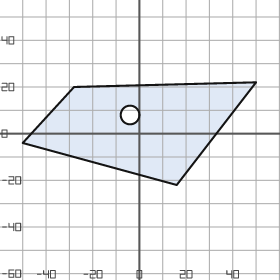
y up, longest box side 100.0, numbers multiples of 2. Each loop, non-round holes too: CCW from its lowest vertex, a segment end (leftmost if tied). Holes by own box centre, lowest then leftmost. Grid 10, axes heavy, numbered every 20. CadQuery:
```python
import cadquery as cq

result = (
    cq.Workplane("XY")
    .moveTo(16.0, -22.0)
    .lineTo(50.0, 22.0)
    .lineTo(-28.0, 20.0)
    .lineTo(-50.0, -4.0)
    .close()
    .moveTo(-4.0, 8.0)
    .circle(4.0)
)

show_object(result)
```